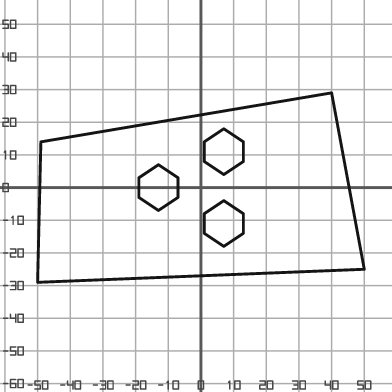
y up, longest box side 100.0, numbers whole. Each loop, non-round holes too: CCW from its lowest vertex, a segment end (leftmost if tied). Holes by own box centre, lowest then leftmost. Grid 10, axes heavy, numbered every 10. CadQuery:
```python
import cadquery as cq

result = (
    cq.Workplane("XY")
    .moveTo(-50.0, -29.0)
    .lineTo(50.0, -25.0)
    .lineTo(40.0, 29.0)
    .lineTo(-49.0, 14.0)
    .close()
    .moveTo(7.0, -18.0)
    .lineTo(13.0, -14.0)
    .lineTo(13.0, -8.0)
    .lineTo(7.0, -4.0)
    .lineTo(1.0, -8.0)
    .lineTo(1.0, -14.0)
    .close()
    .moveTo(-13.0, -7.0)
    .lineTo(-7.0, -3.0)
    .lineTo(-7.0, 3.0)
    .lineTo(-13.0, 7.0)
    .lineTo(-19.0, 3.0)
    .lineTo(-19.0, -3.0)
    .close()
    .moveTo(7.0, 4.0)
    .lineTo(13.0, 8.0)
    .lineTo(13.0, 14.0)
    .lineTo(7.0, 18.0)
    .lineTo(1.0, 14.0)
    .lineTo(1.0, 8.0)
    .close()
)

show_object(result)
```